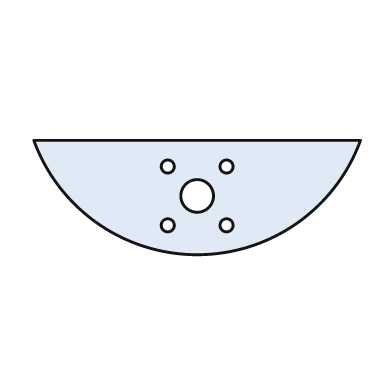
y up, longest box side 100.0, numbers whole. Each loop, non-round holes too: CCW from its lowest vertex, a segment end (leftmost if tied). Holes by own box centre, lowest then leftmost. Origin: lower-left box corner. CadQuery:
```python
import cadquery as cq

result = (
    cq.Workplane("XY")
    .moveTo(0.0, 35.0)
    .threePointArc((50.0, 0.0), (100.0, 35.0))
    .close()
    .moveTo(41.0, 9.0)
    .circle(2.0)
    .moveTo(59.0, 9.0)
    .circle(2.0)
    .moveTo(50.0, 18.0)
    .circle(5.0)
    .moveTo(41.0, 27.0)
    .circle(2.0)
    .moveTo(59.0, 27.0)
    .circle(2.0)
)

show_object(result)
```